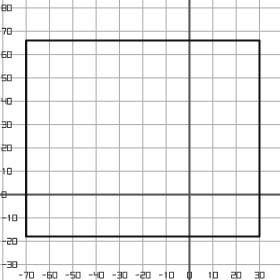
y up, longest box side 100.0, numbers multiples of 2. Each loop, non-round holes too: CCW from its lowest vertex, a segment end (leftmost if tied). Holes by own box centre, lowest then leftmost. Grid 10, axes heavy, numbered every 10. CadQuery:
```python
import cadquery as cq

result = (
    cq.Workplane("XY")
    .moveTo(-70.0, -18.0)
    .lineTo(30.0, -18.0)
    .lineTo(30.0, 66.0)
    .lineTo(-70.0, 66.0)
    .close()
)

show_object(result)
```